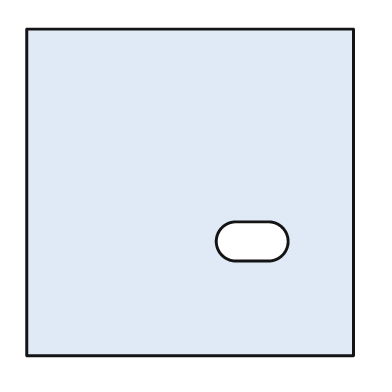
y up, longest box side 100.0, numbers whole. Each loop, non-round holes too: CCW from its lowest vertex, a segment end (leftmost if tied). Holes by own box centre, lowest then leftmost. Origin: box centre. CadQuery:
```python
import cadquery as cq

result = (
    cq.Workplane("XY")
    .moveTo(-50.0, -50.0)
    .lineTo(50.0, -50.0)
    .lineTo(50.0, 50.0)
    .lineTo(-50.0, 50.0)
    .close()
    .moveTo(14.0, -21.0)
    .lineTo(24.0, -21.0)
    .threePointArc((30.0, -15.0), (24.0, -9.0))
    .lineTo(14.0, -9.0)
    .threePointArc((8.0, -15.0), (14.0, -21.0))
    .close()
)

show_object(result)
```